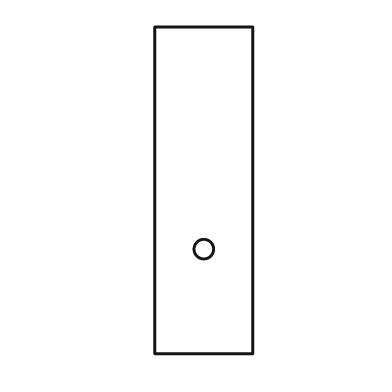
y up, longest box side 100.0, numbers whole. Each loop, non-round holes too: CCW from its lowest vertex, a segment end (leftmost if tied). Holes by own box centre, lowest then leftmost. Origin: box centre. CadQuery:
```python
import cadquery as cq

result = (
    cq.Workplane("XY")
    .moveTo(-15.0, -50.0)
    .lineTo(15.0, -50.0)
    .lineTo(15.0, 50.0)
    .lineTo(-15.0, 50.0)
    .close()
    .moveTo(0.0, -18.0)
    .circle(3.0)
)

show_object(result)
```